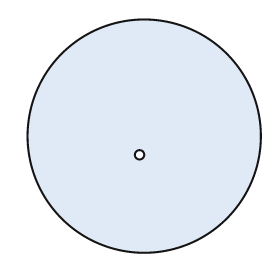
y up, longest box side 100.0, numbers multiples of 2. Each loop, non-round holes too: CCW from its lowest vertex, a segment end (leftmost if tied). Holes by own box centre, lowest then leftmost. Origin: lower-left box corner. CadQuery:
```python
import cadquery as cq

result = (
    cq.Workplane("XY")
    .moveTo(50.0, 50.0)
    .circle(50.0)
    .moveTo(48.0, 42.0)
    .circle(2.0)
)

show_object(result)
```